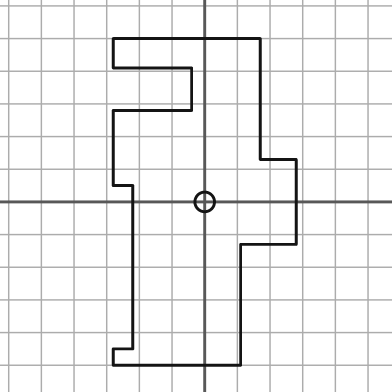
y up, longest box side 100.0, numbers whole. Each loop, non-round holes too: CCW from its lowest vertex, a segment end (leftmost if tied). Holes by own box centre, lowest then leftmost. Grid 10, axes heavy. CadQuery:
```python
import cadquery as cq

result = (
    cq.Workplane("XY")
    .moveTo(-28.0, -50.0)
    .lineTo(11.0, -50.0)
    .lineTo(11.0, -13.0)
    .lineTo(28.0, -13.0)
    .lineTo(28.0, 13.0)
    .lineTo(17.0, 13.0)
    .lineTo(17.0, 50.0)
    .lineTo(-28.0, 50.0)
    .lineTo(-28.0, 41.0)
    .lineTo(-4.0, 41.0)
    .lineTo(-4.0, 28.0)
    .lineTo(-28.0, 28.0)
    .lineTo(-28.0, 5.0)
    .lineTo(-22.0, 5.0)
    .lineTo(-22.0, -45.0)
    .lineTo(-28.0, -45.0)
    .close()
    .moveTo(0.0, 0.0)
    .circle(3.0)
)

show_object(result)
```